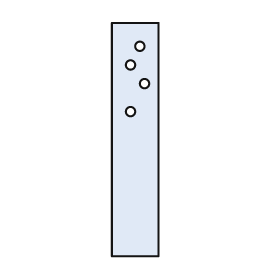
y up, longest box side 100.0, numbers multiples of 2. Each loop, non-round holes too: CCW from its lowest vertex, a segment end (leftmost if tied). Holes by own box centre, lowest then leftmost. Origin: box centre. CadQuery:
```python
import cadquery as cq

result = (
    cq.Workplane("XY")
    .moveTo(-10.0, -50.0)
    .lineTo(10.0, -50.0)
    .lineTo(10.0, 50.0)
    .lineTo(-10.0, 50.0)
    .close()
    .moveTo(-2.0, 12.0)
    .circle(2.0)
    .moveTo(4.0, 24.0)
    .circle(2.0)
    .moveTo(-2.0, 32.0)
    .circle(2.0)
    .moveTo(2.0, 40.0)
    .circle(2.0)
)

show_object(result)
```